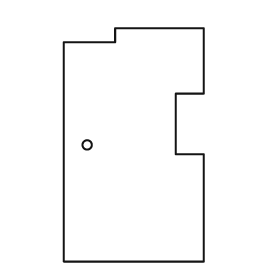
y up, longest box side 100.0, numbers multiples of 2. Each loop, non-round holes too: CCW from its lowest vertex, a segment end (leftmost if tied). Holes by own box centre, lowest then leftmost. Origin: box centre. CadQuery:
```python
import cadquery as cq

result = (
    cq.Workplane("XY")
    .moveTo(-30.0, -50.0)
    .lineTo(30.0, -50.0)
    .lineTo(30.0, -4.0)
    .lineTo(18.0, -4.0)
    .lineTo(18.0, 22.0)
    .lineTo(30.0, 22.0)
    .lineTo(30.0, 50.0)
    .lineTo(-8.0, 50.0)
    .lineTo(-8.0, 44.0)
    .lineTo(-30.0, 44.0)
    .close()
    .moveTo(-20.0, 0.0)
    .circle(2.0)
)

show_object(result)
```